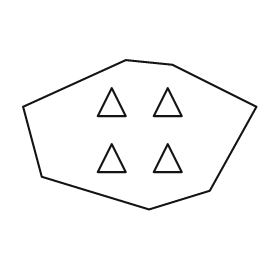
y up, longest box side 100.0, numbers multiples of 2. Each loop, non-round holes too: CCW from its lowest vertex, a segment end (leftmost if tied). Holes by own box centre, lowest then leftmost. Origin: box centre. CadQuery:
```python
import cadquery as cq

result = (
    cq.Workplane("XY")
    .moveTo(4.0, -32.0)
    .lineTo(30.0, -24.0)
    .lineTo(50.0, 12.0)
    .lineTo(14.0, 30.0)
    .lineTo(-6.0, 32.0)
    .lineTo(-50.0, 12.0)
    .lineTo(-42.0, -18.0)
    .close()
    .moveTo(-18.0, -16.0)
    .lineTo(-6.0, -16.0)
    .lineTo(-12.0, -4.0)
    .close()
    .moveTo(6.0, -16.0)
    .lineTo(18.0, -16.0)
    .lineTo(12.0, -4.0)
    .close()
    .moveTo(-18.0, 8.0)
    .lineTo(-6.0, 8.0)
    .lineTo(-12.0, 20.0)
    .close()
    .moveTo(6.0, 8.0)
    .lineTo(18.0, 8.0)
    .lineTo(12.0, 20.0)
    .close()
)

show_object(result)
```